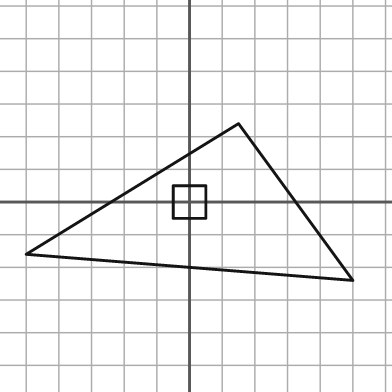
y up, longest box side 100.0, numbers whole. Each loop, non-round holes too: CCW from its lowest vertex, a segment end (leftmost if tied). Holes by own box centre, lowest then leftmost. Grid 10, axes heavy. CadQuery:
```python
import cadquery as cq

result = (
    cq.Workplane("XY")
    .moveTo(50.0, -24.0)
    .lineTo(15.0, 24.0)
    .lineTo(-50.0, -16.0)
    .close()
    .moveTo(-5.0, -5.0)
    .lineTo(5.0, -5.0)
    .lineTo(5.0, 5.0)
    .lineTo(-5.0, 5.0)
    .close()
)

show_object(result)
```